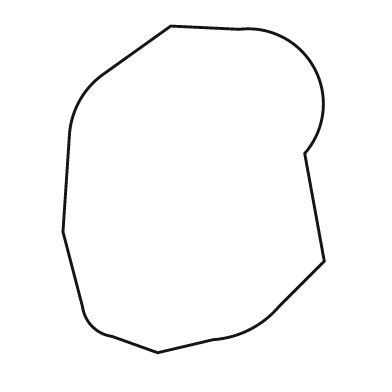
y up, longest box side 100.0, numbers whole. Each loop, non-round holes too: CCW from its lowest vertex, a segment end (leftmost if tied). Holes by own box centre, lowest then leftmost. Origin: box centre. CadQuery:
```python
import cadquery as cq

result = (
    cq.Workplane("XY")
    .moveTo(-11.0, -50.0)
    .lineTo(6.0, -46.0)
    .threePointArc((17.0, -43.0), (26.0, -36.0))
    .lineTo(40.0, -22.0)
    .lineTo(34.0, 11.0)
    .threePointArc((37.0, 37.0), (14.0, 49.0))
    .lineTo(-7.0, 50.0)
    .lineTo(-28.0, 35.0)
    .threePointArc((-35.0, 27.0), (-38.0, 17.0))
    .lineTo(-40.0, -13.0)
    .lineTo(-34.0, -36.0)
    .threePointArc((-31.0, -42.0), (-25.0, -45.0))
    .close()
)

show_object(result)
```